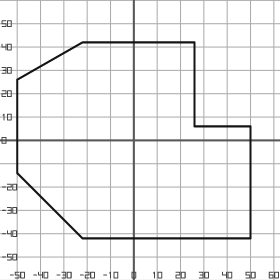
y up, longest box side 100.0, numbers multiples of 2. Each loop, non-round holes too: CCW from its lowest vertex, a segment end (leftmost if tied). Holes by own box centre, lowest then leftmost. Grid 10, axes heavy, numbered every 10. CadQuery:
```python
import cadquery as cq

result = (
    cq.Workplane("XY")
    .moveTo(-22.0, -42.0)
    .lineTo(50.0, -42.0)
    .lineTo(50.0, 6.0)
    .lineTo(26.0, 6.0)
    .lineTo(26.0, 42.0)
    .lineTo(-22.0, 42.0)
    .lineTo(-50.0, 26.0)
    .lineTo(-50.0, -14.0)
    .close()
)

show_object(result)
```